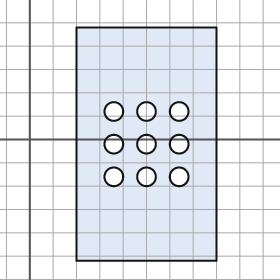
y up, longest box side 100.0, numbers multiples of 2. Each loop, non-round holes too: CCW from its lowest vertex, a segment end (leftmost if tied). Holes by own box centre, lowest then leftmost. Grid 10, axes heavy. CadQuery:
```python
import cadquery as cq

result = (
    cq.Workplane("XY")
    .moveTo(20.0, -52.0)
    .lineTo(80.0, -52.0)
    .lineTo(80.0, 48.0)
    .lineTo(20.0, 48.0)
    .close()
    .moveTo(36.0, -16.0)
    .circle(4.0)
    .moveTo(50.0, -16.0)
    .circle(4.0)
    .moveTo(64.0, -16.0)
    .circle(4.0)
    .moveTo(36.0, -2.0)
    .circle(4.0)
    .moveTo(50.0, -2.0)
    .circle(4.0)
    .moveTo(64.0, -2.0)
    .circle(4.0)
    .moveTo(36.0, 12.0)
    .circle(4.0)
    .moveTo(50.0, 12.0)
    .circle(4.0)
    .moveTo(64.0, 12.0)
    .circle(4.0)
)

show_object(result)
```